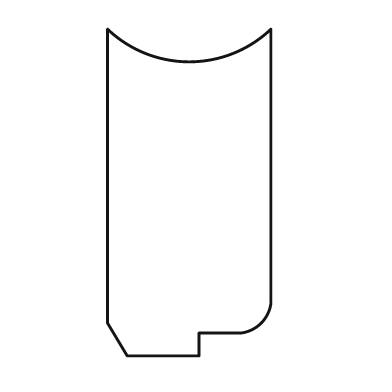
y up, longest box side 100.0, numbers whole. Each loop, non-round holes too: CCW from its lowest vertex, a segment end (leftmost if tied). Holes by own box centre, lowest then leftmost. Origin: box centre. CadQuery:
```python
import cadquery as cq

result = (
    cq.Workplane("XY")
    .moveTo(-19.0, -50.0)
    .lineTo(3.0, -50.0)
    .lineTo(3.0, -43.0)
    .lineTo(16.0, -43.0)
    .threePointArc((22.0, -40.0), (25.0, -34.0))
    .lineTo(25.0, 50.0)
    .threePointArc((0.0, 40.0), (-25.0, 50.0))
    .lineTo(-25.0, -40.0)
    .close()
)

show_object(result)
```